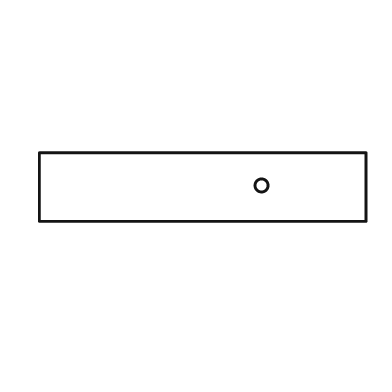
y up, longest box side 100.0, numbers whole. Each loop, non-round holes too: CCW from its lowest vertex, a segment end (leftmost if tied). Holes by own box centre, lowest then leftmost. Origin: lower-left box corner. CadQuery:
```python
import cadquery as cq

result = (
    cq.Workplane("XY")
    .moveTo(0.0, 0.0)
    .lineTo(100.0, 0.0)
    .lineTo(100.0, 21.0)
    .lineTo(0.0, 21.0)
    .close()
    .moveTo(68.0, 11.0)
    .circle(2.0)
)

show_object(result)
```